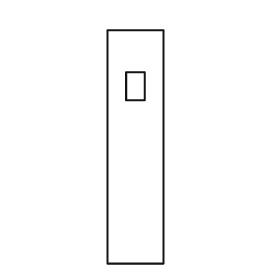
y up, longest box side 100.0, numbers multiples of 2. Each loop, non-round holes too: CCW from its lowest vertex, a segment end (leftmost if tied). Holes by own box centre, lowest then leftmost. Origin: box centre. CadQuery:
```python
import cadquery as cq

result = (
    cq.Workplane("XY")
    .moveTo(-12.0, -50.0)
    .lineTo(12.0, -50.0)
    .lineTo(12.0, 50.0)
    .lineTo(-12.0, 50.0)
    .close()
    .moveTo(-4.0, 20.0)
    .lineTo(4.0, 20.0)
    .lineTo(4.0, 32.0)
    .lineTo(-4.0, 32.0)
    .close()
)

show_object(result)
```